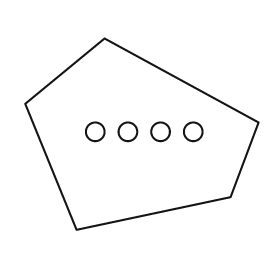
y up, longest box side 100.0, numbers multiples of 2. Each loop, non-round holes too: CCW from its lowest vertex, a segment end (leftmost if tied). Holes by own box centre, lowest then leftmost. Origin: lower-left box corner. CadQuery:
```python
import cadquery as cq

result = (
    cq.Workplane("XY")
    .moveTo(22.0, 0.0)
    .lineTo(88.0, 14.0)
    .lineTo(100.0, 46.0)
    .lineTo(34.0, 82.0)
    .lineTo(0.0, 54.0)
    .close()
    .moveTo(30.0, 42.0)
    .circle(4.0)
    .moveTo(44.0, 42.0)
    .circle(4.0)
    .moveTo(58.0, 42.0)
    .circle(4.0)
    .moveTo(72.0, 42.0)
    .circle(4.0)
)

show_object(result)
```